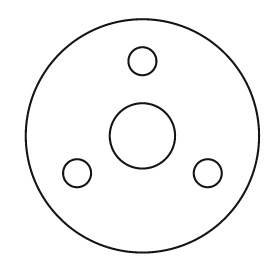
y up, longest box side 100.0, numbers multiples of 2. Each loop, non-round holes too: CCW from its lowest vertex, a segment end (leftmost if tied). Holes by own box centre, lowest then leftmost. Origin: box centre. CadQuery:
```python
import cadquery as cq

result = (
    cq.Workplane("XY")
    .moveTo(0.0, 0.0)
    .circle(50.0)
    .moveTo(-28.0, -16.0)
    .circle(6.0)
    .moveTo(28.0, -16.0)
    .circle(6.0)
    .moveTo(0.0, 0.0)
    .circle(14.0)
    .moveTo(0.0, 32.0)
    .circle(6.0)
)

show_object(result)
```